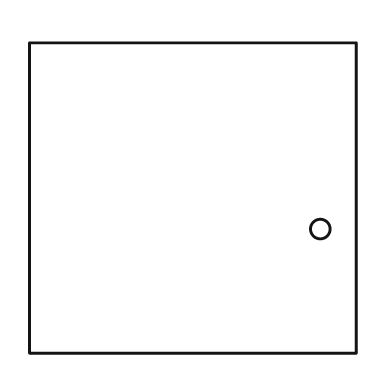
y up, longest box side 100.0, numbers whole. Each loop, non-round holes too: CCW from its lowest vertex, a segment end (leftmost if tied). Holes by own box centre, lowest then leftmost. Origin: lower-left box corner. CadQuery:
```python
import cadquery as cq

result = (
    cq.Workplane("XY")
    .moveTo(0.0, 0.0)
    .lineTo(100.0, 0.0)
    .lineTo(100.0, 95.0)
    .lineTo(0.0, 95.0)
    .close()
    .moveTo(89.0, 38.0)
    .circle(3.0)
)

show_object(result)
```